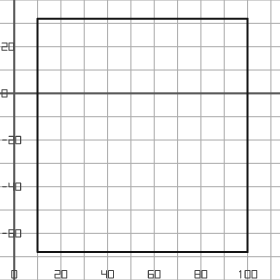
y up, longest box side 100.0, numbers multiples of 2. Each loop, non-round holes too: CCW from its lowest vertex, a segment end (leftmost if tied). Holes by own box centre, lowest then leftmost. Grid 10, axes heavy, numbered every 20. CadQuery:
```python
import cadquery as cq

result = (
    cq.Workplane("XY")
    .moveTo(10.0, -68.0)
    .lineTo(100.0, -68.0)
    .lineTo(100.0, 32.0)
    .lineTo(10.0, 32.0)
    .close()
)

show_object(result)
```